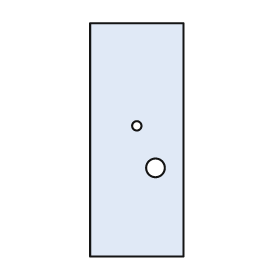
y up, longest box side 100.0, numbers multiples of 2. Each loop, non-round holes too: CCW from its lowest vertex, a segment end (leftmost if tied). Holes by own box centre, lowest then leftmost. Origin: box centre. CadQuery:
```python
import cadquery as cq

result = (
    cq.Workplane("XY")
    .moveTo(-20.0, -50.0)
    .lineTo(20.0, -50.0)
    .lineTo(20.0, 50.0)
    .lineTo(-20.0, 50.0)
    .close()
    .moveTo(8.0, -12.0)
    .circle(4.0)
    .moveTo(0.0, 6.0)
    .circle(2.0)
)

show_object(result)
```